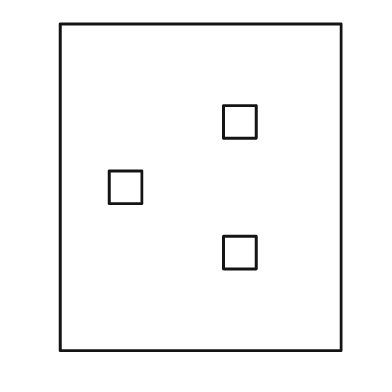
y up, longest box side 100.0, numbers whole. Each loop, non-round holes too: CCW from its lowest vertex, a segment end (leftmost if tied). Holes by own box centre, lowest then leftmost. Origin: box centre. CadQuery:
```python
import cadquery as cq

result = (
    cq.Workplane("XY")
    .moveTo(-43.0, -50.0)
    .lineTo(43.0, -50.0)
    .lineTo(43.0, 50.0)
    .lineTo(-43.0, 50.0)
    .close()
    .moveTo(7.0, -25.0)
    .lineTo(17.0, -25.0)
    .lineTo(17.0, -15.0)
    .lineTo(7.0, -15.0)
    .close()
    .moveTo(-28.0, -5.0)
    .lineTo(-18.0, -5.0)
    .lineTo(-18.0, 5.0)
    .lineTo(-28.0, 5.0)
    .close()
    .moveTo(7.0, 15.0)
    .lineTo(17.0, 15.0)
    .lineTo(17.0, 25.0)
    .lineTo(7.0, 25.0)
    .close()
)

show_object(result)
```